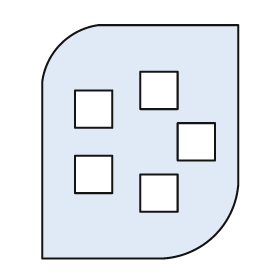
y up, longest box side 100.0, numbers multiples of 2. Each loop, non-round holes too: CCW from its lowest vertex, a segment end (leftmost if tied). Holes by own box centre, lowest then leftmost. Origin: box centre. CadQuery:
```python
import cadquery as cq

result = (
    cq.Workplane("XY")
    .moveTo(-42.0, -50.0)
    .lineTo(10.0, -50.0)
    .threePointArc((32.0, -40.0), (42.0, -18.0))
    .lineTo(42.0, 50.0)
    .lineTo(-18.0, 50.0)
    .threePointArc((-34.0, 42.0), (-42.0, 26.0))
    .close()
    .moveTo(0.0, -30.0)
    .lineTo(16.0, -30.0)
    .lineTo(16.0, -14.0)
    .lineTo(0.0, -14.0)
    .close()
    .moveTo(-28.0, -22.0)
    .lineTo(-12.0, -22.0)
    .lineTo(-12.0, -6.0)
    .lineTo(-28.0, -6.0)
    .close()
    .moveTo(16.0, -8.0)
    .lineTo(32.0, -8.0)
    .lineTo(32.0, 8.0)
    .lineTo(16.0, 8.0)
    .close()
    .moveTo(-28.0, 6.0)
    .lineTo(-12.0, 6.0)
    .lineTo(-12.0, 22.0)
    .lineTo(-28.0, 22.0)
    .close()
    .moveTo(0.0, 14.0)
    .lineTo(16.0, 14.0)
    .lineTo(16.0, 30.0)
    .lineTo(0.0, 30.0)
    .close()
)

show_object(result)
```